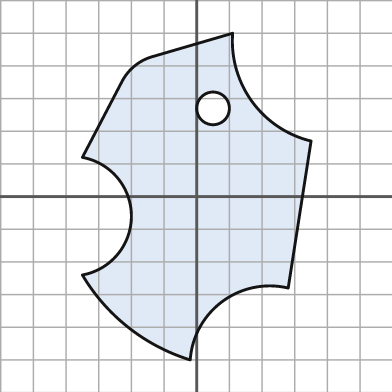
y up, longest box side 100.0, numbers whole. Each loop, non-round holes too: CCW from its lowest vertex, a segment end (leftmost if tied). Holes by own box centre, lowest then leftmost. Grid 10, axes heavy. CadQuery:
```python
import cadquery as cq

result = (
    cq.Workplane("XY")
    .moveTo(-2.0, -50.0)
    .threePointArc((8.0, -32.0), (28.0, -28.0))
    .lineTo(35.0, 17.0)
    .threePointArc((17.0, 29.0), (11.0, 50.0))
    .lineTo(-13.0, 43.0)
    .threePointArc((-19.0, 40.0), (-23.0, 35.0))
    .lineTo(-35.0, 12.0)
    .threePointArc((-20.0, -6.0), (-35.0, -24.0))
    .threePointArc((-21.0, -40.0), (-2.0, -50.0))
    .close()
    .moveTo(5.0, 27.0)
    .circle(5.0)
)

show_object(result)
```